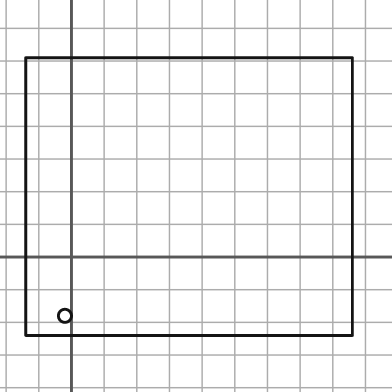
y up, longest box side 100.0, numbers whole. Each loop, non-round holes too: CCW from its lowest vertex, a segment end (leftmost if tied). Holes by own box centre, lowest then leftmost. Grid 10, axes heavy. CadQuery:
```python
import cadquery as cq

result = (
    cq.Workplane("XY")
    .moveTo(-14.0, -24.0)
    .lineTo(86.0, -24.0)
    .lineTo(86.0, 61.0)
    .lineTo(-14.0, 61.0)
    .close()
    .moveTo(-2.0, -18.0)
    .circle(2.0)
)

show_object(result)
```